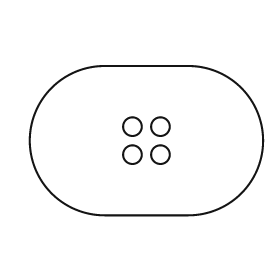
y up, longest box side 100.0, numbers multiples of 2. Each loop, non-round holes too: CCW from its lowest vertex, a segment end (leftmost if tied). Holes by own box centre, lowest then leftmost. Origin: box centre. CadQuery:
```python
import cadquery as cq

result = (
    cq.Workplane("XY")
    .moveTo(-18.0, -32.0)
    .lineTo(18.0, -32.0)
    .threePointArc((50.0, 0.0), (18.0, 32.0))
    .lineTo(-18.0, 32.0)
    .threePointArc((-50.0, 0.0), (-18.0, -32.0))
    .close()
    .moveTo(-6.0, -6.0)
    .circle(4.0)
    .moveTo(6.0, -6.0)
    .circle(4.0)
    .moveTo(-6.0, 6.0)
    .circle(4.0)
    .moveTo(6.0, 6.0)
    .circle(4.0)
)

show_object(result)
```